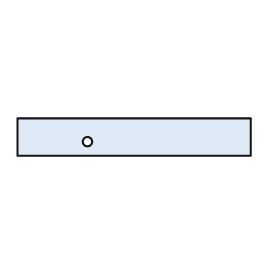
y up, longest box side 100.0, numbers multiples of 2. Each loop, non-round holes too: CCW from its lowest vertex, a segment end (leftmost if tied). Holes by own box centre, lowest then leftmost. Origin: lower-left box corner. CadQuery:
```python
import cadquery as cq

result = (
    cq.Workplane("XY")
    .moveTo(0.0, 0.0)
    .lineTo(100.0, 0.0)
    .lineTo(100.0, 16.0)
    .lineTo(0.0, 16.0)
    .close()
    .moveTo(30.0, 6.0)
    .circle(2.0)
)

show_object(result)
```